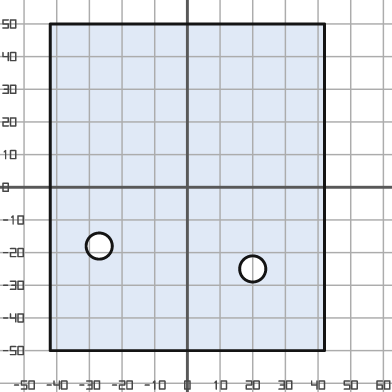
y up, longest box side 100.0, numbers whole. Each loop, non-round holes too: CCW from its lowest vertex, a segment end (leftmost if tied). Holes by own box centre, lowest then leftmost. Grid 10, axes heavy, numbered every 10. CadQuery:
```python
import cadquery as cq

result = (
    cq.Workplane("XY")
    .moveTo(-42.0, -50.0)
    .lineTo(42.0, -50.0)
    .lineTo(42.0, 50.0)
    .lineTo(-42.0, 50.0)
    .close()
    .moveTo(20.0, -25.0)
    .circle(4.0)
    .moveTo(-27.0, -18.0)
    .circle(4.0)
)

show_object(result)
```